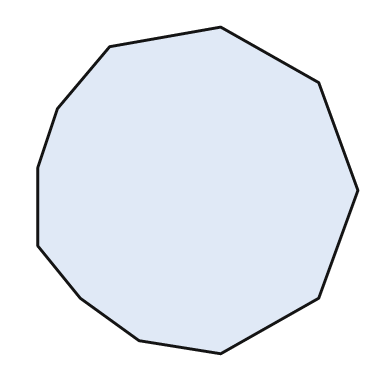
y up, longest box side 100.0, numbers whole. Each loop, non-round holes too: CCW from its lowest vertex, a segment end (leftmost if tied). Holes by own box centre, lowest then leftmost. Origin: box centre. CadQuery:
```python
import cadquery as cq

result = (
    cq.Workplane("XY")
    .moveTo(7.0, -50.0)
    .lineTo(37.0, -33.0)
    .lineTo(49.0, 0.0)
    .lineTo(37.0, 33.0)
    .lineTo(7.0, 50.0)
    .lineTo(-27.0, 44.0)
    .lineTo(-43.0, 25.0)
    .lineTo(-49.0, 7.0)
    .lineTo(-49.0, -17.0)
    .lineTo(-36.0, -33.0)
    .lineTo(-18.0, -46.0)
    .close()
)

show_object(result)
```